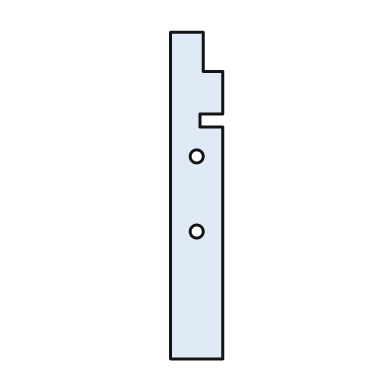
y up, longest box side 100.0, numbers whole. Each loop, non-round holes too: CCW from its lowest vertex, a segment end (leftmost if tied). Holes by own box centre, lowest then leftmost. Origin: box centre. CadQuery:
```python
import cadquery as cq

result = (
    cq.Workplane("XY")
    .moveTo(-8.0, -50.0)
    .lineTo(8.0, -50.0)
    .lineTo(8.0, 21.0)
    .lineTo(1.0, 21.0)
    .lineTo(1.0, 25.0)
    .lineTo(8.0, 25.0)
    .lineTo(8.0, 38.0)
    .lineTo(2.0, 38.0)
    .lineTo(2.0, 50.0)
    .lineTo(-8.0, 50.0)
    .close()
    .moveTo(0.0, -11.0)
    .circle(2.0)
    .moveTo(0.0, 12.0)
    .circle(2.0)
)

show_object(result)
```